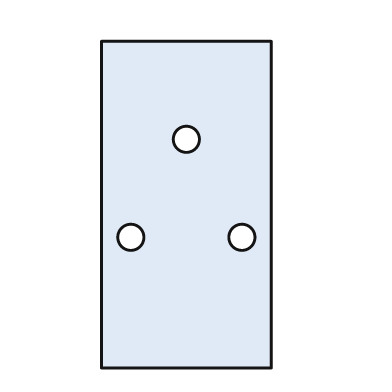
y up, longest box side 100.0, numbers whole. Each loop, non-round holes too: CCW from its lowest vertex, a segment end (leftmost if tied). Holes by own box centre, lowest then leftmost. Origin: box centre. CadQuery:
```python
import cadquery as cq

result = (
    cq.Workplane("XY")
    .moveTo(-26.0, -50.0)
    .lineTo(26.0, -50.0)
    .lineTo(26.0, 50.0)
    .lineTo(-26.0, 50.0)
    .close()
    .moveTo(-17.0, -10.0)
    .circle(4.0)
    .moveTo(17.0, -10.0)
    .circle(4.0)
    .moveTo(0.0, 20.0)
    .circle(4.0)
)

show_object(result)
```